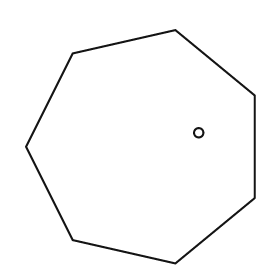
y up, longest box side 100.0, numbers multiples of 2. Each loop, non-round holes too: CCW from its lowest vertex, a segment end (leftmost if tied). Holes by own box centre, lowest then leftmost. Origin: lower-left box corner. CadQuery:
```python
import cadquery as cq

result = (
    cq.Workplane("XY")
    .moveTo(64.0, 0.0)
    .lineTo(98.0, 28.0)
    .lineTo(98.0, 72.0)
    .lineTo(64.0, 100.0)
    .lineTo(20.0, 90.0)
    .lineTo(0.0, 50.0)
    .lineTo(20.0, 10.0)
    .close()
    .moveTo(74.0, 56.0)
    .circle(2.0)
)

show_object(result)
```